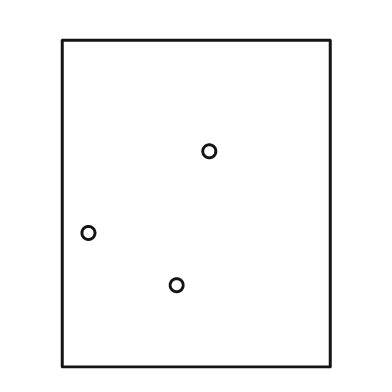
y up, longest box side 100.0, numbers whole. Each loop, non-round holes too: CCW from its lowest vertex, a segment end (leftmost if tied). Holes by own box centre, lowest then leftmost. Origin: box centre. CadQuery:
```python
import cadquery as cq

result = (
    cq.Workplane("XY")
    .moveTo(-41.0, -50.0)
    .lineTo(41.0, -50.0)
    .lineTo(41.0, 50.0)
    .lineTo(-41.0, 50.0)
    .close()
    .moveTo(-6.0, -25.0)
    .circle(2.0)
    .moveTo(-33.0, -9.0)
    .circle(2.0)
    .moveTo(4.0, 16.0)
    .circle(2.0)
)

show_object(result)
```